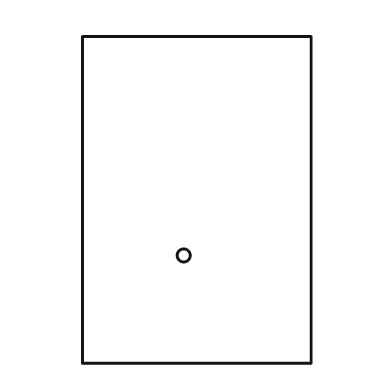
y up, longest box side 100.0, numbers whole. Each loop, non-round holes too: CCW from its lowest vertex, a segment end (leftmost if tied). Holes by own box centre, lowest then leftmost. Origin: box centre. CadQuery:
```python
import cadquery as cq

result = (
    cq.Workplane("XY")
    .moveTo(-35.0, -50.0)
    .lineTo(35.0, -50.0)
    .lineTo(35.0, 50.0)
    .lineTo(-35.0, 50.0)
    .close()
    .moveTo(-4.0, -17.0)
    .circle(2.0)
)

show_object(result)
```